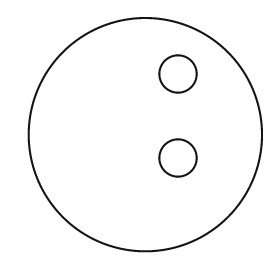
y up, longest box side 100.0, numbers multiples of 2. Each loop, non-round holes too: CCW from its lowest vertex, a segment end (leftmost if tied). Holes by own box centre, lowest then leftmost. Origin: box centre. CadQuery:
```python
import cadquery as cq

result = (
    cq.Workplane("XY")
    .moveTo(0.0, 0.0)
    .circle(50.0)
    .moveTo(14.0, -10.0)
    .circle(8.0)
    .moveTo(14.0, 26.0)
    .circle(8.0)
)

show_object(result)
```